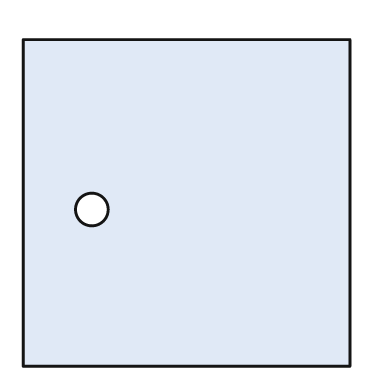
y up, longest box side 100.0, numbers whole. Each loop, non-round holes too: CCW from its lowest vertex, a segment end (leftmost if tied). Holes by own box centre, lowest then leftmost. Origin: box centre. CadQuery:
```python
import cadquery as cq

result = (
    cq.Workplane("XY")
    .moveTo(-50.0, -50.0)
    .lineTo(50.0, -50.0)
    .lineTo(50.0, 50.0)
    .lineTo(-50.0, 50.0)
    .close()
    .moveTo(-29.0, -2.0)
    .circle(5.0)
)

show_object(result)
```